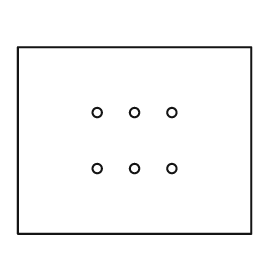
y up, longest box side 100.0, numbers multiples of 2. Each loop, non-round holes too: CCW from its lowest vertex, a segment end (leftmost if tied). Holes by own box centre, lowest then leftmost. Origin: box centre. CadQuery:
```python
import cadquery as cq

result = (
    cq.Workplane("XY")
    .moveTo(-50.0, -40.0)
    .lineTo(50.0, -40.0)
    .lineTo(50.0, 40.0)
    .lineTo(-50.0, 40.0)
    .close()
    .moveTo(-16.0, -12.0)
    .circle(2.0)
    .moveTo(0.0, -12.0)
    .circle(2.0)
    .moveTo(16.0, -12.0)
    .circle(2.0)
    .moveTo(-16.0, 12.0)
    .circle(2.0)
    .moveTo(0.0, 12.0)
    .circle(2.0)
    .moveTo(16.0, 12.0)
    .circle(2.0)
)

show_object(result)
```